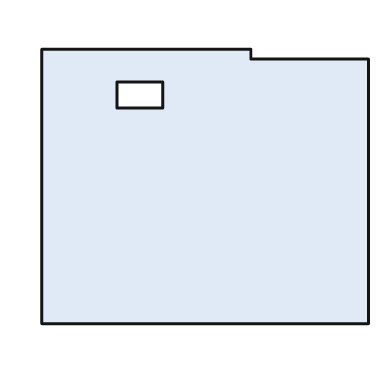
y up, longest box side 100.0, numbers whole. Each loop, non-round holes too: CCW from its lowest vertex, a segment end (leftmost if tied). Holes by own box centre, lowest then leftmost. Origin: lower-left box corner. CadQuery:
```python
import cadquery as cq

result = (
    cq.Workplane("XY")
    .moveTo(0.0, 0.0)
    .lineTo(100.0, 0.0)
    .lineTo(100.0, 81.0)
    .lineTo(64.0, 81.0)
    .lineTo(64.0, 84.0)
    .lineTo(0.0, 84.0)
    .close()
    .moveTo(23.0, 66.0)
    .lineTo(37.0, 66.0)
    .lineTo(37.0, 74.0)
    .lineTo(23.0, 74.0)
    .close()
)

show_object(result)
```